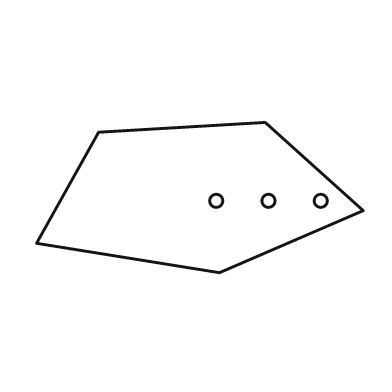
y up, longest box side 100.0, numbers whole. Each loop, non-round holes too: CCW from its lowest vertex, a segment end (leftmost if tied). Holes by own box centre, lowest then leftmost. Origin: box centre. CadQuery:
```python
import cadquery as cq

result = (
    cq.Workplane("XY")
    .moveTo(6.0, -23.0)
    .lineTo(50.0, -4.0)
    .lineTo(20.0, 23.0)
    .lineTo(-31.0, 20.0)
    .lineTo(-50.0, -14.0)
    .close()
    .moveTo(5.0, -1.0)
    .circle(2.0)
    .moveTo(21.0, -1.0)
    .circle(2.0)
    .moveTo(37.0, -1.0)
    .circle(2.0)
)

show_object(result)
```